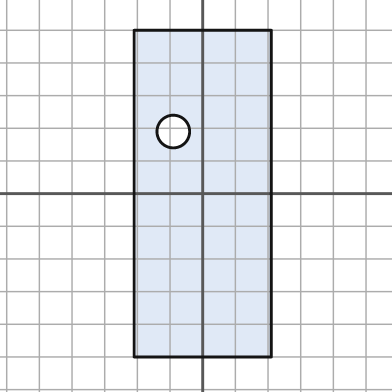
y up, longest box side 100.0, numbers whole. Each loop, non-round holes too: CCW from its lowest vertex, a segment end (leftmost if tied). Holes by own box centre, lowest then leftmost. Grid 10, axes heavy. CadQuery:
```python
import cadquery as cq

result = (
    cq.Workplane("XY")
    .moveTo(-21.0, -50.0)
    .lineTo(21.0, -50.0)
    .lineTo(21.0, 50.0)
    .lineTo(-21.0, 50.0)
    .close()
    .moveTo(-9.0, 19.0)
    .circle(5.0)
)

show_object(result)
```